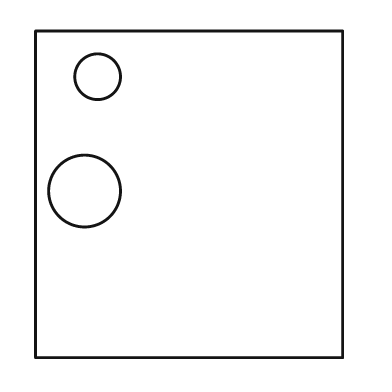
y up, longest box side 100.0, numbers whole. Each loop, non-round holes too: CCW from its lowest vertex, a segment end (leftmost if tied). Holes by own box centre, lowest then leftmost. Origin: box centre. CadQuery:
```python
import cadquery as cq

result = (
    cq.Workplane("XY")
    .moveTo(-47.0, -50.0)
    .lineTo(47.0, -50.0)
    .lineTo(47.0, 50.0)
    .lineTo(-47.0, 50.0)
    .close()
    .moveTo(-32.0, 1.0)
    .circle(11.0)
    .moveTo(-28.0, 36.0)
    .circle(7.0)
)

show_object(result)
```